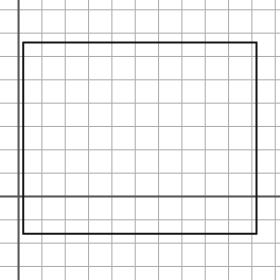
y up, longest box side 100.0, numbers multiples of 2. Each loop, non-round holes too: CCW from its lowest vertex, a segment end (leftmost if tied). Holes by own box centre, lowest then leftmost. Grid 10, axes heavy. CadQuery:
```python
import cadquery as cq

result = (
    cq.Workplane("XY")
    .moveTo(2.0, -16.0)
    .lineTo(102.0, -16.0)
    .lineTo(102.0, 66.0)
    .lineTo(2.0, 66.0)
    .close()
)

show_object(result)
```